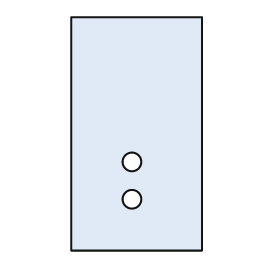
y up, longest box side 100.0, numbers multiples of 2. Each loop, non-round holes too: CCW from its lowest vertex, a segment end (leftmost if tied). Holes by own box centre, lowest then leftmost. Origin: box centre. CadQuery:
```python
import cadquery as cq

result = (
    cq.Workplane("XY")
    .moveTo(-28.0, -50.0)
    .lineTo(28.0, -50.0)
    .lineTo(28.0, 50.0)
    .lineTo(-28.0, 50.0)
    .close()
    .moveTo(-2.0, -28.0)
    .circle(4.0)
    .moveTo(-2.0, -12.0)
    .circle(4.0)
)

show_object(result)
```